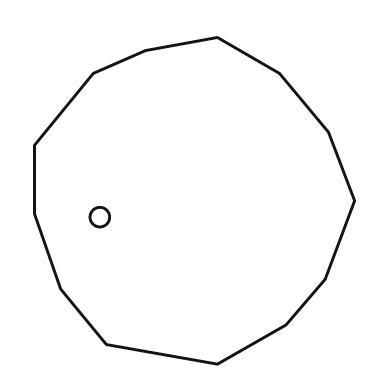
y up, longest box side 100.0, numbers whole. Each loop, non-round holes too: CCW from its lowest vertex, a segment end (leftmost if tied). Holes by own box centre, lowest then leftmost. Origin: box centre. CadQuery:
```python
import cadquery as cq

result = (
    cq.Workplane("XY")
    .moveTo(7.0, -50.0)
    .lineTo(28.0, -38.0)
    .lineTo(40.0, -24.0)
    .lineTo(49.0, 0.0)
    .lineTo(41.0, 21.0)
    .lineTo(26.0, 39.0)
    .lineTo(7.0, 50.0)
    .lineTo(-15.0, 46.0)
    .lineTo(-31.0, 39.0)
    .lineTo(-49.0, 17.0)
    .lineTo(-49.0, -4.0)
    .lineTo(-41.0, -27.0)
    .lineTo(-27.0, -44.0)
    .close()
    .moveTo(-29.0, -5.0)
    .circle(3.0)
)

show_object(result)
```